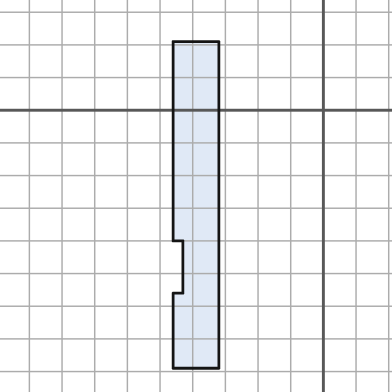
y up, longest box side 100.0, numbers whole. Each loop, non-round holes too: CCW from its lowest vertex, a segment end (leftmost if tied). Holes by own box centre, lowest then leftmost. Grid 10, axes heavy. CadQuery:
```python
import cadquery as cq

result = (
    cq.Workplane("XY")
    .moveTo(-46.0, -79.0)
    .lineTo(-32.0, -79.0)
    .lineTo(-32.0, 21.0)
    .lineTo(-46.0, 21.0)
    .lineTo(-46.0, -40.0)
    .lineTo(-43.0, -40.0)
    .lineTo(-43.0, -56.0)
    .lineTo(-46.0, -56.0)
    .close()
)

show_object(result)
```